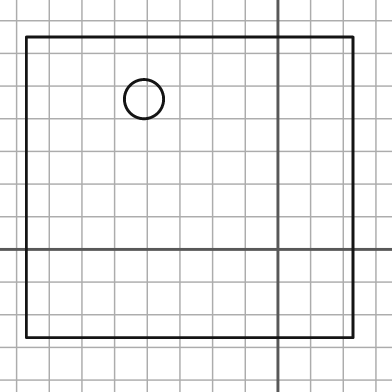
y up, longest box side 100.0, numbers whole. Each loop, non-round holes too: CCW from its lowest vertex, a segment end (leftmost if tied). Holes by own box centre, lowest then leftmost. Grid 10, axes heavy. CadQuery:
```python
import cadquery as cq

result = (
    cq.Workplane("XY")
    .moveTo(-77.0, -27.0)
    .lineTo(23.0, -27.0)
    .lineTo(23.0, 65.0)
    .lineTo(-77.0, 65.0)
    .close()
    .moveTo(-41.0, 46.0)
    .circle(6.0)
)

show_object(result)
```